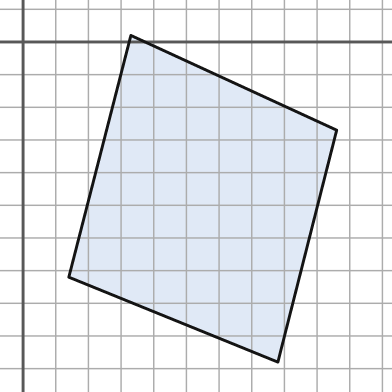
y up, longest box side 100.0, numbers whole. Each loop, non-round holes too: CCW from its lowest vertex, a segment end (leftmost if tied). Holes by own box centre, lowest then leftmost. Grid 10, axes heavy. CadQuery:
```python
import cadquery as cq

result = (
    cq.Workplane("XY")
    .moveTo(78.0, -98.0)
    .lineTo(96.0, -27.0)
    .lineTo(33.0, 2.0)
    .lineTo(14.0, -72.0)
    .close()
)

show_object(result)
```